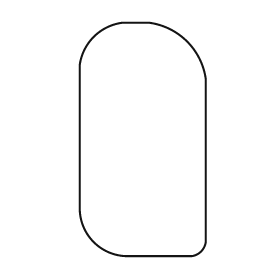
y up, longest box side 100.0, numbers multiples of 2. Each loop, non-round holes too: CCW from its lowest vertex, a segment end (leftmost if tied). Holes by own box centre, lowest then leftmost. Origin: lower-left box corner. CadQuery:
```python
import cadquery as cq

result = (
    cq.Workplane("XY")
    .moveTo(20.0, 0.0)
    .lineTo(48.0, 0.0)
    .threePointArc((52.0, 2.0), (54.0, 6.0))
    .lineTo(54.0, 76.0)
    .threePointArc((46.0, 92.0), (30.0, 100.0))
    .lineTo(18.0, 100.0)
    .threePointArc((6.0, 94.0), (0.0, 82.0))
    .lineTo(0.0, 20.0)
    .threePointArc((6.0, 6.0), (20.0, 0.0))
    .close()
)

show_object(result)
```